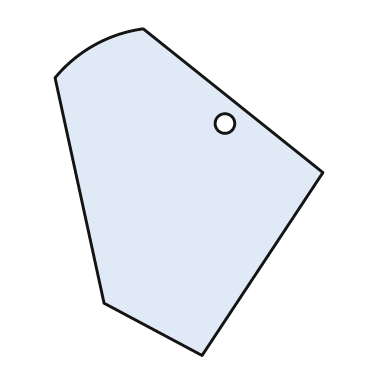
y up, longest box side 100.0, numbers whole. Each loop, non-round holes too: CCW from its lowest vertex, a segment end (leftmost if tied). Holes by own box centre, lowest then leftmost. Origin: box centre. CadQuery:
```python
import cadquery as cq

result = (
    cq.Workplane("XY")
    .moveTo(4.0, -50.0)
    .lineTo(41.0, 6.0)
    .lineTo(-14.0, 50.0)
    .threePointArc((-29.0, 45.0), (-41.0, 35.0))
    .lineTo(-26.0, -34.0)
    .close()
    .moveTo(11.0, 21.0)
    .circle(3.0)
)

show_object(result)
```